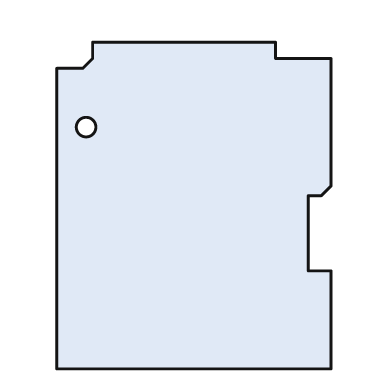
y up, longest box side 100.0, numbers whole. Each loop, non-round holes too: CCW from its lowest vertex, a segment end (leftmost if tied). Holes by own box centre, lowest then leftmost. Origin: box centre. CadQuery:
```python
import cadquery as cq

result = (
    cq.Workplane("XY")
    .moveTo(-42.0, -50.0)
    .lineTo(42.0, -50.0)
    .lineTo(42.0, -20.0)
    .lineTo(35.0, -20.0)
    .lineTo(35.0, 3.0)
    .lineTo(39.0, 3.0)
    .lineTo(42.0, 6.0)
    .lineTo(42.0, 45.0)
    .lineTo(25.0, 45.0)
    .lineTo(25.0, 50.0)
    .lineTo(-31.0, 50.0)
    .lineTo(-31.0, 45.0)
    .lineTo(-34.0, 42.0)
    .lineTo(-42.0, 42.0)
    .close()
    .moveTo(-33.0, 24.0)
    .circle(3.0)
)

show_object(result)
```